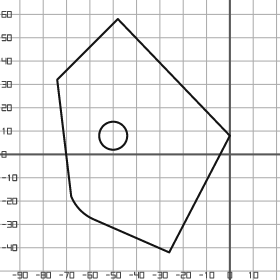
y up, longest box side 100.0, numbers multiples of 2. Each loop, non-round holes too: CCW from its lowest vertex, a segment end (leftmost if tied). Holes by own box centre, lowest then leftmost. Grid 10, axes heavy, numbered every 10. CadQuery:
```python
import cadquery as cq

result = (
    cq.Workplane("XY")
    .moveTo(-26.0, -42.0)
    .lineTo(0.0, 8.0)
    .lineTo(-48.0, 58.0)
    .lineTo(-74.0, 32.0)
    .lineTo(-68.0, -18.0)
    .threePointArc((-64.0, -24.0), (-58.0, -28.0))
    .close()
    .moveTo(-50.0, 8.0)
    .circle(6.0)
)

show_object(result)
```